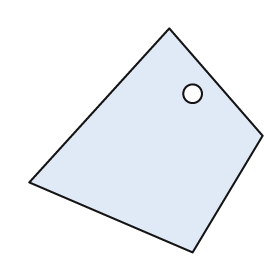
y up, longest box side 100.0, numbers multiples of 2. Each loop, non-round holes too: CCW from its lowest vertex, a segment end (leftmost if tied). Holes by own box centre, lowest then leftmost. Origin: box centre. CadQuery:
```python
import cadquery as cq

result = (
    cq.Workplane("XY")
    .moveTo(20.0, -48.0)
    .lineTo(50.0, 2.0)
    .lineTo(10.0, 48.0)
    .lineTo(-50.0, -18.0)
    .close()
    .moveTo(20.0, 20.0)
    .circle(4.0)
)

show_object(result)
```